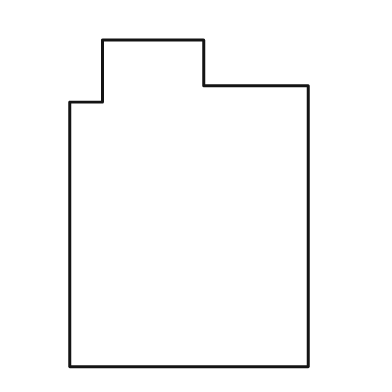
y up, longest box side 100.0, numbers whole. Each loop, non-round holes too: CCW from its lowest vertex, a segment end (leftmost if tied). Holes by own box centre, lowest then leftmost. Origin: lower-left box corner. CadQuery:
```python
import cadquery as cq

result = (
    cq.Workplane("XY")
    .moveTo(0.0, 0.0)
    .lineTo(73.0, 0.0)
    .lineTo(73.0, 86.0)
    .lineTo(41.0, 86.0)
    .lineTo(41.0, 100.0)
    .lineTo(10.0, 100.0)
    .lineTo(10.0, 81.0)
    .lineTo(0.0, 81.0)
    .close()
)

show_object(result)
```